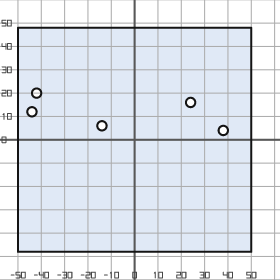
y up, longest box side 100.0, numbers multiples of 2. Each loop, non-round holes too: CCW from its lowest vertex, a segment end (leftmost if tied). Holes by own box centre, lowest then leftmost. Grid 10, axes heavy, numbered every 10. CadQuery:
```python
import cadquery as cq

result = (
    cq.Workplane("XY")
    .moveTo(-50.0, -48.0)
    .lineTo(50.0, -48.0)
    .lineTo(50.0, 48.0)
    .lineTo(-50.0, 48.0)
    .close()
    .moveTo(38.0, 4.0)
    .circle(2.0)
    .moveTo(-14.0, 6.0)
    .circle(2.0)
    .moveTo(-44.0, 12.0)
    .circle(2.0)
    .moveTo(24.0, 16.0)
    .circle(2.0)
    .moveTo(-42.0, 20.0)
    .circle(2.0)
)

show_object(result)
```